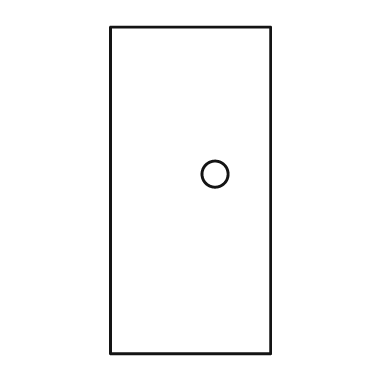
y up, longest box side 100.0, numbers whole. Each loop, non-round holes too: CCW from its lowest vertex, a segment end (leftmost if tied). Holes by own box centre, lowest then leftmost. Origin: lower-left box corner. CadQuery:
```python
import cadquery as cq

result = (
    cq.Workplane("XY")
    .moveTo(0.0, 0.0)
    .lineTo(49.0, 0.0)
    .lineTo(49.0, 100.0)
    .lineTo(0.0, 100.0)
    .close()
    .moveTo(32.0, 55.0)
    .circle(4.0)
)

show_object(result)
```